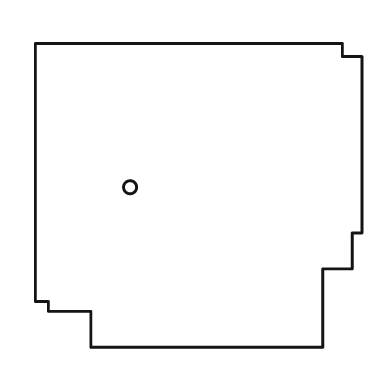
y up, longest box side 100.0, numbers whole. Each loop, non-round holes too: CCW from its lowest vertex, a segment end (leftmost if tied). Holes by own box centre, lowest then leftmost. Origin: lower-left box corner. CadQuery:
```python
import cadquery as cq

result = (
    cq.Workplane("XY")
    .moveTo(17.0, 0.0)
    .lineTo(88.0, 0.0)
    .lineTo(88.0, 24.0)
    .lineTo(97.0, 24.0)
    .lineTo(97.0, 35.0)
    .lineTo(100.0, 35.0)
    .lineTo(100.0, 89.0)
    .lineTo(94.0, 89.0)
    .lineTo(94.0, 93.0)
    .lineTo(0.0, 93.0)
    .lineTo(0.0, 14.0)
    .lineTo(4.0, 14.0)
    .lineTo(4.0, 11.0)
    .lineTo(17.0, 11.0)
    .close()
    .moveTo(29.0, 49.0)
    .circle(2.0)
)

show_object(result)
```